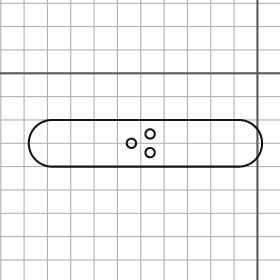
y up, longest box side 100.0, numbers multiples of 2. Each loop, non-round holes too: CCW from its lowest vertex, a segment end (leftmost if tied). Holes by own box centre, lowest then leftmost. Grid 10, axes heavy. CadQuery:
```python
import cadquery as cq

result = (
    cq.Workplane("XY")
    .moveTo(-88.0, -40.0)
    .lineTo(-8.0, -40.0)
    .threePointArc((2.0, -30.0), (-8.0, -20.0))
    .lineTo(-88.0, -20.0)
    .threePointArc((-98.0, -30.0), (-88.0, -40.0))
    .close()
    .moveTo(-46.0, -34.0)
    .circle(2.0)
    .moveTo(-54.0, -30.0)
    .circle(2.0)
    .moveTo(-46.0, -26.0)
    .circle(2.0)
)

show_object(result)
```